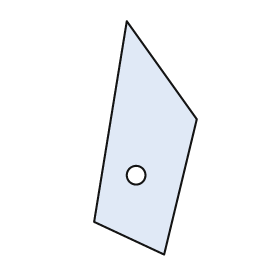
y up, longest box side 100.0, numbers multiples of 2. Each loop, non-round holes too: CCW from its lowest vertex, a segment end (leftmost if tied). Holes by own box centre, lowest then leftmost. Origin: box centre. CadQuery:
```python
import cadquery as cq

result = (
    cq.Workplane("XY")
    .moveTo(8.0, -50.0)
    .lineTo(22.0, 8.0)
    .lineTo(-8.0, 50.0)
    .lineTo(-22.0, -36.0)
    .close()
    .moveTo(-4.0, -16.0)
    .circle(4.0)
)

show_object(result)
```